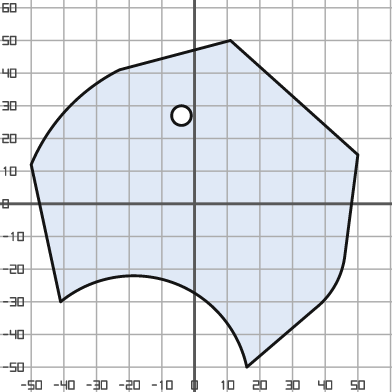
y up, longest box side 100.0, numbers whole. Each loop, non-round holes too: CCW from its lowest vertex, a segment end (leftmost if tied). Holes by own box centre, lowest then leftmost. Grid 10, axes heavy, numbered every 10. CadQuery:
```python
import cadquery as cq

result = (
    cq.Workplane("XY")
    .moveTo(16.0, -50.0)
    .lineTo(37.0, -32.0)
    .threePointArc((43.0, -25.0), (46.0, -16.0))
    .lineTo(50.0, 15.0)
    .lineTo(11.0, 50.0)
    .lineTo(-23.0, 41.0)
    .threePointArc((-39.0, 29.0), (-50.0, 12.0))
    .lineTo(-41.0, -30.0)
    .threePointArc((-7.0, -24.0), (16.0, -50.0))
    .close()
    .moveTo(-4.0, 27.0)
    .circle(3.0)
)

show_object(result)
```